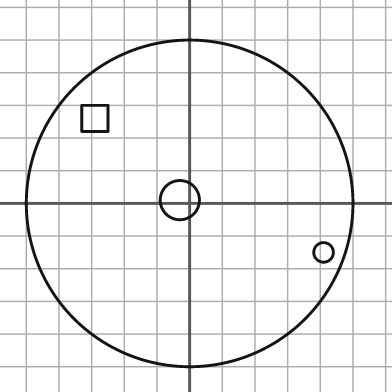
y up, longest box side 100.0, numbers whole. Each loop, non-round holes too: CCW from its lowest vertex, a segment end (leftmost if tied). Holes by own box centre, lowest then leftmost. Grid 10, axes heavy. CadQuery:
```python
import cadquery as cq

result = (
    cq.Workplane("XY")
    .moveTo(0.0, 0.0)
    .circle(50.0)
    .moveTo(41.0, -15.0)
    .circle(3.0)
    .moveTo(-3.0, 1.0)
    .circle(6.0)
    .moveTo(-33.0, 22.0)
    .lineTo(-25.0, 22.0)
    .lineTo(-25.0, 30.0)
    .lineTo(-33.0, 30.0)
    .close()
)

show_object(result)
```